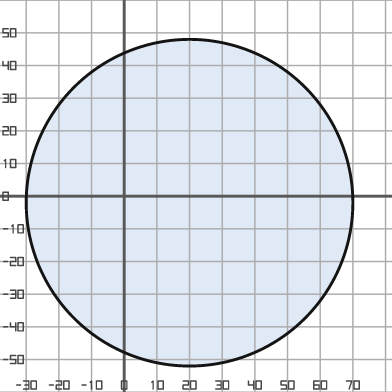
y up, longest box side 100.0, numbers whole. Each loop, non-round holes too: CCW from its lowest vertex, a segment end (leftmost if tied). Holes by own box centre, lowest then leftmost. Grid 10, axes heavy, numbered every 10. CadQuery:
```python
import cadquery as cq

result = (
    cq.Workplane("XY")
    .moveTo(20.0, -2.0)
    .circle(50.0)
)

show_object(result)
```